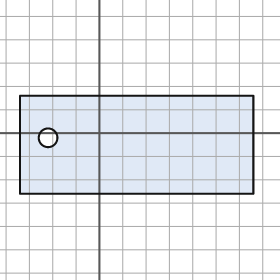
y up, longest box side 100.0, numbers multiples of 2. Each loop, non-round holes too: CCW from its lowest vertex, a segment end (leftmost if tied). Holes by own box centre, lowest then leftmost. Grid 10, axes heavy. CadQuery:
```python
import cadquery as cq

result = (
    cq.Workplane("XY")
    .moveTo(-34.0, -26.0)
    .lineTo(66.0, -26.0)
    .lineTo(66.0, 16.0)
    .lineTo(-34.0, 16.0)
    .close()
    .moveTo(-22.0, -2.0)
    .circle(4.0)
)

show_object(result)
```